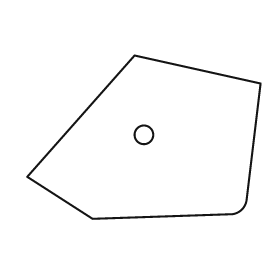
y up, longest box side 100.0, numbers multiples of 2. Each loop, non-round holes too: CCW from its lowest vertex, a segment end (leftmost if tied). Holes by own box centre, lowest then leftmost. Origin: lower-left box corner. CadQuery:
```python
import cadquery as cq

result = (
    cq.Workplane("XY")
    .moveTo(28.0, 0.0)
    .lineTo(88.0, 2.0)
    .threePointArc((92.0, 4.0), (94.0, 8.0))
    .lineTo(100.0, 58.0)
    .lineTo(46.0, 70.0)
    .lineTo(0.0, 18.0)
    .close()
    .moveTo(50.0, 36.0)
    .circle(4.0)
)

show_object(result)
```